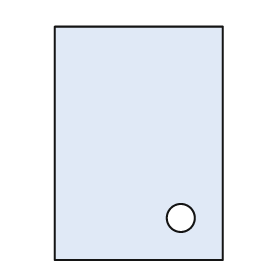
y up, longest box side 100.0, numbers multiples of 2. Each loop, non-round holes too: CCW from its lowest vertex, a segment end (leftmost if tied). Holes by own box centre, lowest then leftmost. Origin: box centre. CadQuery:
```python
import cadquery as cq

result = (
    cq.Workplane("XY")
    .moveTo(-36.0, -50.0)
    .lineTo(36.0, -50.0)
    .lineTo(36.0, 50.0)
    .lineTo(-36.0, 50.0)
    .close()
    .moveTo(18.0, -32.0)
    .circle(6.0)
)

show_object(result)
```